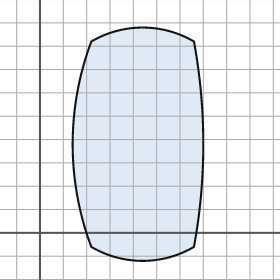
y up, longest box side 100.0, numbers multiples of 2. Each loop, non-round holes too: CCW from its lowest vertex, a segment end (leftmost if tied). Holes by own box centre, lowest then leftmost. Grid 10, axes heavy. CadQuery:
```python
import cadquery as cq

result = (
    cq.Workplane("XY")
    .moveTo(22.0, -6.0)
    .threePointArc((44.0, -12.0), (66.0, -6.0))
    .threePointArc((70.0, 38.0), (66.0, 82.0))
    .threePointArc((44.0, 88.0), (22.0, 82.0))
    .threePointArc((14.0, 38.0), (22.0, -6.0))
    .close()
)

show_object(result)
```